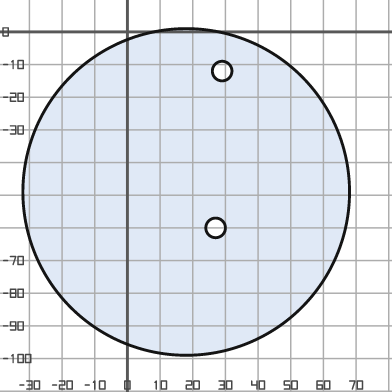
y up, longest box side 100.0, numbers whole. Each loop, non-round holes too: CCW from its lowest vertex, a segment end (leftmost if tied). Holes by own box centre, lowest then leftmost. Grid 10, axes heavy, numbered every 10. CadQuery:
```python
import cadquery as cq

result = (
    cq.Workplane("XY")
    .moveTo(18.0, -49.0)
    .circle(50.0)
    .moveTo(27.0, -60.0)
    .circle(3.0)
    .moveTo(29.0, -12.0)
    .circle(3.0)
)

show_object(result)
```